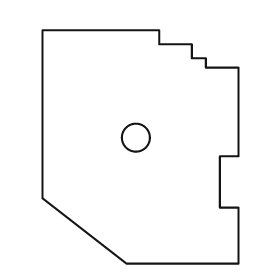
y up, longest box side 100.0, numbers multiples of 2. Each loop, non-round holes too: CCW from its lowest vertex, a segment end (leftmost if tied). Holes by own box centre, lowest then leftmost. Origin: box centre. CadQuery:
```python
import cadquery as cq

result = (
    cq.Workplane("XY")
    .moveTo(-6.0, -50.0)
    .lineTo(42.0, -50.0)
    .lineTo(42.0, -26.0)
    .lineTo(34.0, -26.0)
    .lineTo(34.0, -4.0)
    .lineTo(42.0, -4.0)
    .lineTo(42.0, 34.0)
    .lineTo(28.0, 34.0)
    .lineTo(28.0, 38.0)
    .lineTo(22.0, 38.0)
    .lineTo(22.0, 44.0)
    .lineTo(8.0, 44.0)
    .lineTo(8.0, 50.0)
    .lineTo(-42.0, 50.0)
    .lineTo(-42.0, -22.0)
    .close()
    .moveTo(-2.0, 4.0)
    .circle(6.0)
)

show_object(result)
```